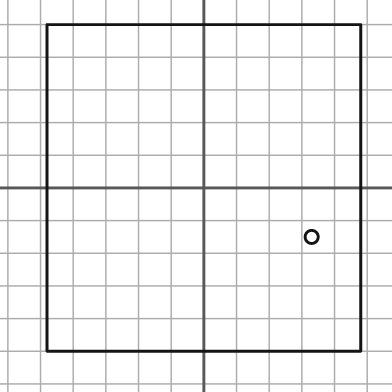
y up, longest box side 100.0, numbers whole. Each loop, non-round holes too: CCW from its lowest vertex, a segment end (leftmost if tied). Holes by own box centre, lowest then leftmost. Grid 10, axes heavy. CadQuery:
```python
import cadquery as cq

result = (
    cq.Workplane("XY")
    .moveTo(-48.0, -50.0)
    .lineTo(48.0, -50.0)
    .lineTo(48.0, 50.0)
    .lineTo(-48.0, 50.0)
    .close()
    .moveTo(33.0, -15.0)
    .circle(2.0)
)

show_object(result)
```